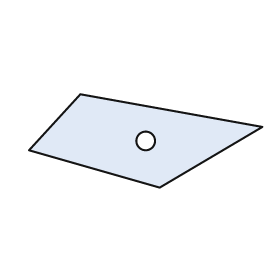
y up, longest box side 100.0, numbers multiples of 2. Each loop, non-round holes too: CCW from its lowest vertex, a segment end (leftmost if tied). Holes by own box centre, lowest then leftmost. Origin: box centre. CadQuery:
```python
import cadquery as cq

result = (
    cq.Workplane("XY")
    .moveTo(6.0, -20.0)
    .lineTo(50.0, 6.0)
    .lineTo(-28.0, 20.0)
    .lineTo(-50.0, -4.0)
    .close()
    .moveTo(0.0, 0.0)
    .circle(4.0)
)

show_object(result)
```